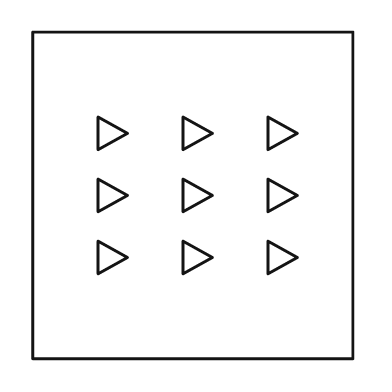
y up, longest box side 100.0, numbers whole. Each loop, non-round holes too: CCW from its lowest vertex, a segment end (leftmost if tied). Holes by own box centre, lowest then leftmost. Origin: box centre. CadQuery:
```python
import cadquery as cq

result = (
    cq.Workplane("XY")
    .moveTo(-49.0, -50.0)
    .lineTo(49.0, -50.0)
    .lineTo(49.0, 50.0)
    .lineTo(-49.0, 50.0)
    .close()
    .moveTo(-29.0, -24.0)
    .lineTo(-20.0, -19.0)
    .lineTo(-29.0, -14.0)
    .close()
    .moveTo(-3.0, -24.0)
    .lineTo(6.0, -19.0)
    .lineTo(-3.0, -14.0)
    .close()
    .moveTo(23.0, -24.0)
    .lineTo(32.0, -19.0)
    .lineTo(23.0, -14.0)
    .close()
    .moveTo(-29.0, -5.0)
    .lineTo(-20.0, 0.0)
    .lineTo(-29.0, 5.0)
    .close()
    .moveTo(-3.0, -5.0)
    .lineTo(6.0, 0.0)
    .lineTo(-3.0, 5.0)
    .close()
    .moveTo(23.0, -5.0)
    .lineTo(32.0, 0.0)
    .lineTo(23.0, 5.0)
    .close()
    .moveTo(-29.0, 14.0)
    .lineTo(-20.0, 19.0)
    .lineTo(-29.0, 24.0)
    .close()
    .moveTo(-3.0, 14.0)
    .lineTo(6.0, 19.0)
    .lineTo(-3.0, 24.0)
    .close()
    .moveTo(23.0, 14.0)
    .lineTo(32.0, 19.0)
    .lineTo(23.0, 24.0)
    .close()
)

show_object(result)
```